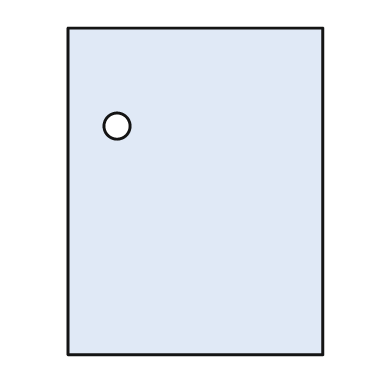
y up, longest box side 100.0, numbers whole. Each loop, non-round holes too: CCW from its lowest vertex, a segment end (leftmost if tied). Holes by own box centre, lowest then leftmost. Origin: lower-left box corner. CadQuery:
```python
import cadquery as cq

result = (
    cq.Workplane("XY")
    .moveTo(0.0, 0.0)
    .lineTo(78.0, 0.0)
    .lineTo(78.0, 100.0)
    .lineTo(0.0, 100.0)
    .close()
    .moveTo(15.0, 70.0)
    .circle(4.0)
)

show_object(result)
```